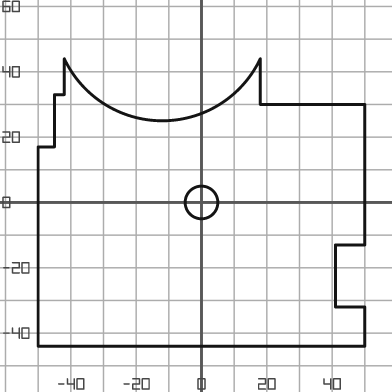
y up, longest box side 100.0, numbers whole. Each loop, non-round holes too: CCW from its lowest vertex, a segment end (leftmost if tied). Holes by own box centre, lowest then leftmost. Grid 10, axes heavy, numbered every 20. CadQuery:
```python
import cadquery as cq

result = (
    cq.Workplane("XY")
    .moveTo(-50.0, -44.0)
    .lineTo(50.0, -44.0)
    .lineTo(50.0, -32.0)
    .lineTo(41.0, -32.0)
    .lineTo(41.0, -13.0)
    .lineTo(50.0, -13.0)
    .lineTo(50.0, 30.0)
    .lineTo(18.0, 30.0)
    .lineTo(18.0, 44.0)
    .threePointArc((-12.0, 25.0), (-42.0, 44.0))
    .lineTo(-42.0, 33.0)
    .lineTo(-45.0, 33.0)
    .lineTo(-45.0, 17.0)
    .lineTo(-50.0, 17.0)
    .close()
    .moveTo(0.0, 0.0)
    .circle(5.0)
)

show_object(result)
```